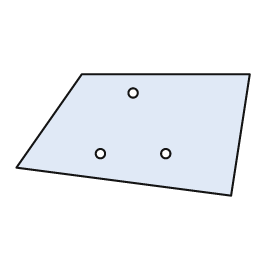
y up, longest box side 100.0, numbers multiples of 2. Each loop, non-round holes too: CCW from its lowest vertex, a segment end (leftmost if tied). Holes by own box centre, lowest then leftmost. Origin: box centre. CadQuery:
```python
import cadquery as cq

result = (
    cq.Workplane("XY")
    .moveTo(42.0, -26.0)
    .lineTo(50.0, 26.0)
    .lineTo(-22.0, 26.0)
    .lineTo(-50.0, -14.0)
    .close()
    .moveTo(-14.0, -8.0)
    .circle(2.0)
    .moveTo(14.0, -8.0)
    .circle(2.0)
    .moveTo(0.0, 18.0)
    .circle(2.0)
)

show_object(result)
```